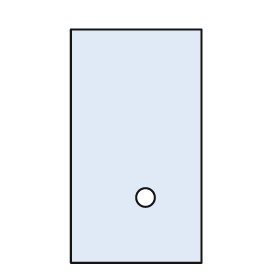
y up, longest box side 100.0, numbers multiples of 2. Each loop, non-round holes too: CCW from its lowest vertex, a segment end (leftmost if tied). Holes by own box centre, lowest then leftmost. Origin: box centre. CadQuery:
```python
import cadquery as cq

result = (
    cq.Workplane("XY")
    .moveTo(-28.0, -50.0)
    .lineTo(28.0, -50.0)
    .lineTo(28.0, 50.0)
    .lineTo(-28.0, 50.0)
    .close()
    .moveTo(4.0, -22.0)
    .circle(4.0)
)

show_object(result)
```